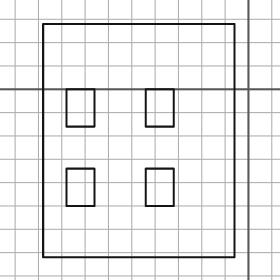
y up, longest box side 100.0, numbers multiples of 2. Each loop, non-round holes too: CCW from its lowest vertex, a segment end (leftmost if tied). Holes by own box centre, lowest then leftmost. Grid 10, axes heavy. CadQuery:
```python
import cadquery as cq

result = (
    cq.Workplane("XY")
    .moveTo(-88.0, -72.0)
    .lineTo(-6.0, -72.0)
    .lineTo(-6.0, 28.0)
    .lineTo(-88.0, 28.0)
    .close()
    .moveTo(-78.0, -50.0)
    .lineTo(-66.0, -50.0)
    .lineTo(-66.0, -34.0)
    .lineTo(-78.0, -34.0)
    .close()
    .moveTo(-44.0, -50.0)
    .lineTo(-32.0, -50.0)
    .lineTo(-32.0, -34.0)
    .lineTo(-44.0, -34.0)
    .close()
    .moveTo(-78.0, -16.0)
    .lineTo(-66.0, -16.0)
    .lineTo(-66.0, 0.0)
    .lineTo(-78.0, 0.0)
    .close()
    .moveTo(-44.0, -16.0)
    .lineTo(-32.0, -16.0)
    .lineTo(-32.0, 0.0)
    .lineTo(-44.0, 0.0)
    .close()
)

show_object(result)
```